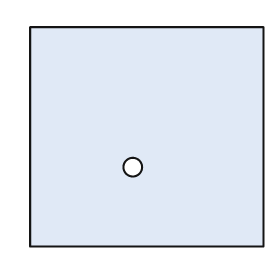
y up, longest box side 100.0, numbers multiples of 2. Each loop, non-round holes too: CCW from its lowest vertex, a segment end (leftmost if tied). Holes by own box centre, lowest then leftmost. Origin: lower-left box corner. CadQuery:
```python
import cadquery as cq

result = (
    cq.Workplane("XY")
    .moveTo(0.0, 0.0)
    .lineTo(100.0, 0.0)
    .lineTo(100.0, 94.0)
    .lineTo(0.0, 94.0)
    .close()
    .moveTo(44.0, 34.0)
    .circle(4.0)
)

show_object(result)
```